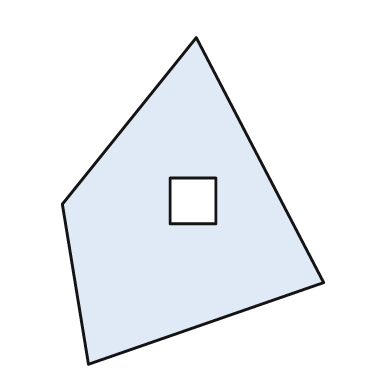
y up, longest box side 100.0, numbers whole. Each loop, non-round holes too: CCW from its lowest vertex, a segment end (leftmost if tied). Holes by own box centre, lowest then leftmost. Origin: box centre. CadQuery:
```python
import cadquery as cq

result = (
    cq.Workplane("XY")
    .moveTo(-32.0, -50.0)
    .lineTo(40.0, -25.0)
    .lineTo(1.0, 50.0)
    .lineTo(-40.0, -1.0)
    .close()
    .moveTo(-7.0, -7.0)
    .lineTo(7.0, -7.0)
    .lineTo(7.0, 7.0)
    .lineTo(-7.0, 7.0)
    .close()
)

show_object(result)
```